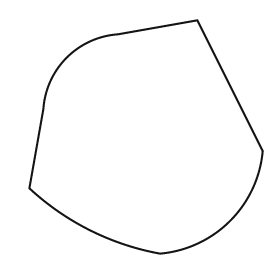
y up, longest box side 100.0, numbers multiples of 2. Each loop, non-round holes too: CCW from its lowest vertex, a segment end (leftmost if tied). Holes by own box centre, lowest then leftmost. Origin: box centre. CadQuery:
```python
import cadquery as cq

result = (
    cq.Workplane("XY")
    .moveTo(6.0, -50.0)
    .threePointArc((36.0, -36.0), (50.0, -6.0))
    .lineTo(22.0, 50.0)
    .lineTo(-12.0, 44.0)
    .threePointArc((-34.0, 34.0), (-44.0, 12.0))
    .lineTo(-50.0, -22.0)
    .threePointArc((-24.0, -40.0), (6.0, -50.0))
    .close()
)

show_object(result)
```